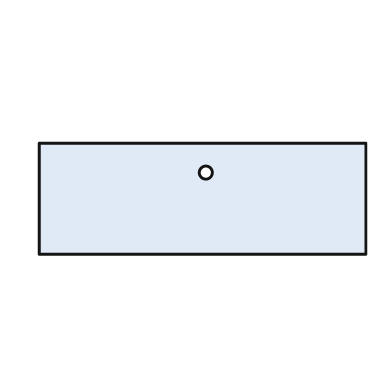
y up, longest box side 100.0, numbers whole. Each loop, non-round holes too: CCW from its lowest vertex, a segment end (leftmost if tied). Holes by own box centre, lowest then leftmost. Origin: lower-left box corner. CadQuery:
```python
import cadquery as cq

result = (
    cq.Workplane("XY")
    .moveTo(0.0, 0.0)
    .lineTo(100.0, 0.0)
    .lineTo(100.0, 34.0)
    .lineTo(0.0, 34.0)
    .close()
    .moveTo(51.0, 25.0)
    .circle(2.0)
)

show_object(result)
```